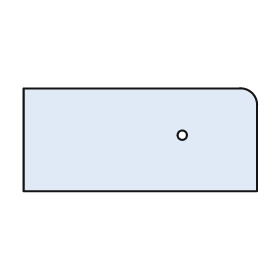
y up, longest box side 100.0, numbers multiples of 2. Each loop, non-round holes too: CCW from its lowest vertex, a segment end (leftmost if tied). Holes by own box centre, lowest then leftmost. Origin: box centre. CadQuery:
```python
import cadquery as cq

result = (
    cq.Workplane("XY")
    .moveTo(-50.0, -22.0)
    .lineTo(50.0, -22.0)
    .lineTo(50.0, 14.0)
    .threePointArc((48.0, 20.0), (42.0, 22.0))
    .lineTo(-50.0, 22.0)
    .close()
    .moveTo(18.0, 2.0)
    .circle(2.0)
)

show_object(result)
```